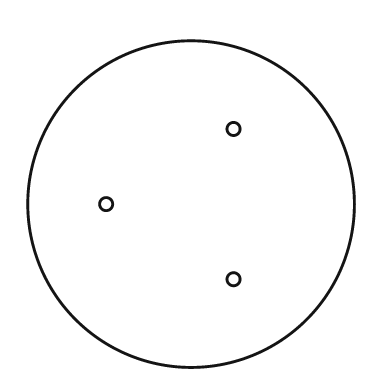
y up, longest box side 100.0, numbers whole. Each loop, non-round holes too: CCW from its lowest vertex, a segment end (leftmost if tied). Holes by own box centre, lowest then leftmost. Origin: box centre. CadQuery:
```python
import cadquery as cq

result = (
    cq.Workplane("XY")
    .moveTo(0.0, 0.0)
    .circle(50.0)
    .moveTo(13.0, -23.0)
    .circle(2.0)
    .moveTo(-26.0, 0.0)
    .circle(2.0)
    .moveTo(13.0, 23.0)
    .circle(2.0)
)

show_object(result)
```